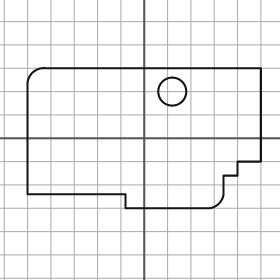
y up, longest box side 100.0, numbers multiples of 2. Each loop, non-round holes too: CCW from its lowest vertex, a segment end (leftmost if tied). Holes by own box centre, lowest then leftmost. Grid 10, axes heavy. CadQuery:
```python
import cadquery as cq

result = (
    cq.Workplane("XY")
    .moveTo(-8.0, -30.0)
    .lineTo(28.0, -30.0)
    .threePointArc((32.0, -28.0), (34.0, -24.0))
    .lineTo(34.0, -16.0)
    .lineTo(40.0, -16.0)
    .lineTo(40.0, -10.0)
    .lineTo(50.0, -10.0)
    .lineTo(50.0, 30.0)
    .lineTo(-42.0, 30.0)
    .threePointArc((-48.0, 28.0), (-50.0, 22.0))
    .lineTo(-50.0, -24.0)
    .lineTo(-8.0, -24.0)
    .close()
    .moveTo(12.0, 20.0)
    .circle(6.0)
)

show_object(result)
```